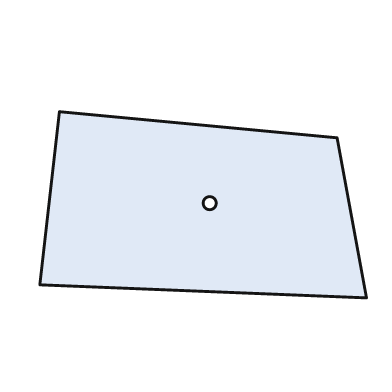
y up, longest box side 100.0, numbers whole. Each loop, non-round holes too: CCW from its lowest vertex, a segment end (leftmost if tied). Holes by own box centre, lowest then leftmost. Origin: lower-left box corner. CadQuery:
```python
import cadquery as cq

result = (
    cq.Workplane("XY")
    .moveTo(100.0, 0.0)
    .lineTo(91.0, 49.0)
    .lineTo(6.0, 57.0)
    .lineTo(0.0, 4.0)
    .close()
    .moveTo(52.0, 29.0)
    .circle(2.0)
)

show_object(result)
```